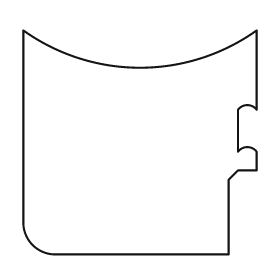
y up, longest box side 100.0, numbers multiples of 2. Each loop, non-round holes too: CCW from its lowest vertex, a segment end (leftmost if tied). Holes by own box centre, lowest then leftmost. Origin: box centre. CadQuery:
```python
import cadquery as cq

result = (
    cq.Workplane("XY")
    .moveTo(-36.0, -48.0)
    .lineTo(38.0, -48.0)
    .lineTo(38.0, -16.0)
    .lineTo(42.0, -12.0)
    .lineTo(50.0, -12.0)
    .lineTo(50.0, -4.0)
    .threePointArc((46.0, -2.0), (42.0, -4.0))
    .lineTo(42.0, 14.0)
    .threePointArc((46.0, 16.0), (50.0, 14.0))
    .lineTo(50.0, 48.0)
    .threePointArc((0.0, 32.0), (-50.0, 48.0))
    .lineTo(-50.0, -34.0)
    .threePointArc((-46.0, -44.0), (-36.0, -48.0))
    .close()
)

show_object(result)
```